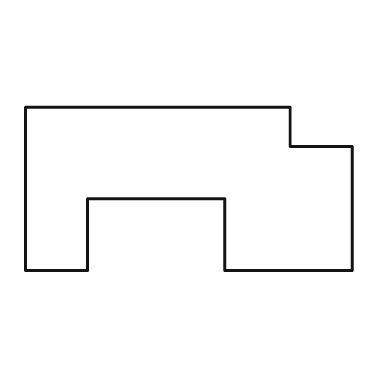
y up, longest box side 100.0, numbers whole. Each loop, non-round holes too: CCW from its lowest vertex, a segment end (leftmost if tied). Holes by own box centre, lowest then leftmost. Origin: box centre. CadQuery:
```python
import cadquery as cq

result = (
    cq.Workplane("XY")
    .moveTo(-50.0, -25.0)
    .lineTo(-31.0, -25.0)
    .lineTo(-31.0, -3.0)
    .lineTo(11.0, -3.0)
    .lineTo(11.0, -25.0)
    .lineTo(50.0, -25.0)
    .lineTo(50.0, 13.0)
    .lineTo(31.0, 13.0)
    .lineTo(31.0, 25.0)
    .lineTo(-50.0, 25.0)
    .close()
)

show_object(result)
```